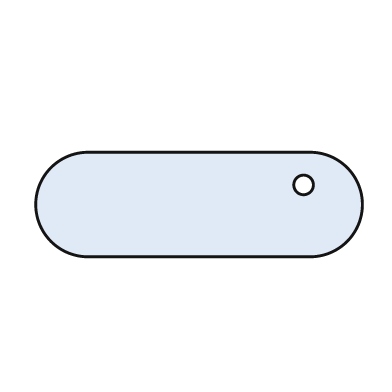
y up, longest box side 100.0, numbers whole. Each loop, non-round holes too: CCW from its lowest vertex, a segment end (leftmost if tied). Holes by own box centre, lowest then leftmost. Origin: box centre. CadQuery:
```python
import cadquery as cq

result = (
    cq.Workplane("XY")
    .moveTo(-34.0, -16.0)
    .lineTo(34.0, -16.0)
    .threePointArc((50.0, 0.0), (34.0, 16.0))
    .lineTo(-34.0, 16.0)
    .threePointArc((-50.0, 0.0), (-34.0, -16.0))
    .close()
    .moveTo(32.0, 6.0)
    .circle(3.0)
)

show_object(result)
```